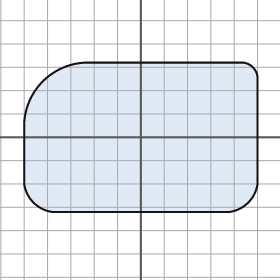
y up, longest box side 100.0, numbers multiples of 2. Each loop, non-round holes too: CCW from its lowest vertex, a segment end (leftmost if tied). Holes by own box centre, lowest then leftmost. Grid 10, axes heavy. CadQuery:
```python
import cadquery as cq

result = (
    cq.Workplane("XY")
    .moveTo(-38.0, -32.0)
    .lineTo(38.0, -32.0)
    .threePointArc((46.0, -28.0), (50.0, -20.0))
    .lineTo(50.0, 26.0)
    .threePointArc((48.0, 30.0), (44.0, 32.0))
    .lineTo(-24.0, 32.0)
    .threePointArc((-42.0, 24.0), (-50.0, 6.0))
    .lineTo(-50.0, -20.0)
    .threePointArc((-46.0, -28.0), (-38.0, -32.0))
    .close()
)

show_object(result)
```